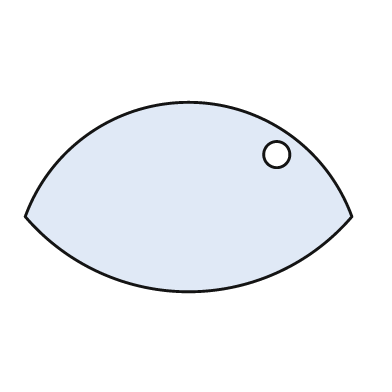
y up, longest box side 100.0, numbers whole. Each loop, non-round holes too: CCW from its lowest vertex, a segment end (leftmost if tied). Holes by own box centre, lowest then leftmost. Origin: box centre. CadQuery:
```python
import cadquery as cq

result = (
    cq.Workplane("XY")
    .moveTo(-50.0, -6.0)
    .threePointArc((0.0, -29.0), (50.0, -6.0))
    .threePointArc((0.0, 29.0), (-50.0, -6.0))
    .close()
    .moveTo(27.0, 13.0)
    .circle(4.0)
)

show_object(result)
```